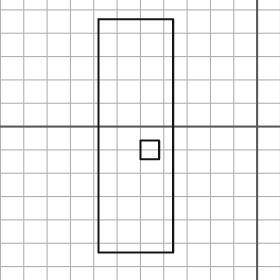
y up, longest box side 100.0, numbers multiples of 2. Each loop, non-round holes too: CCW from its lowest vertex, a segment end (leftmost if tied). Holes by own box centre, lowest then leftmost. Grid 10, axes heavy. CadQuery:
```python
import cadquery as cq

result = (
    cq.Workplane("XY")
    .moveTo(-68.0, -54.0)
    .lineTo(-36.0, -54.0)
    .lineTo(-36.0, 46.0)
    .lineTo(-68.0, 46.0)
    .close()
    .moveTo(-50.0, -14.0)
    .lineTo(-42.0, -14.0)
    .lineTo(-42.0, -6.0)
    .lineTo(-50.0, -6.0)
    .close()
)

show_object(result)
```